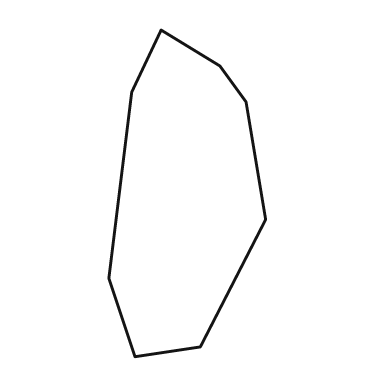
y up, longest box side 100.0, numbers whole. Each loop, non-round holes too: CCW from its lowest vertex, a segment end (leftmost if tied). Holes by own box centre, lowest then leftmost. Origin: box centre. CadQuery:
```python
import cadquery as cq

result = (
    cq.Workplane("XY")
    .moveTo(-16.0, -50.0)
    .lineTo(4.0, -47.0)
    .lineTo(24.0, -8.0)
    .lineTo(18.0, 28.0)
    .lineTo(10.0, 39.0)
    .lineTo(-8.0, 50.0)
    .lineTo(-17.0, 31.0)
    .lineTo(-24.0, -26.0)
    .close()
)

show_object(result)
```